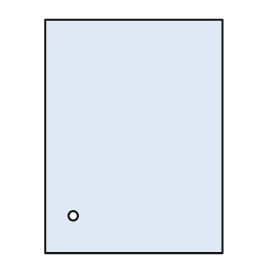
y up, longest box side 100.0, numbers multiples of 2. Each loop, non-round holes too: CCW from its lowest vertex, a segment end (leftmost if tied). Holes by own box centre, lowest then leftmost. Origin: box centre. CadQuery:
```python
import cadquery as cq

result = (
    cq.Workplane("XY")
    .moveTo(-38.0, -50.0)
    .lineTo(38.0, -50.0)
    .lineTo(38.0, 50.0)
    .lineTo(-38.0, 50.0)
    .close()
    .moveTo(-26.0, -34.0)
    .circle(2.0)
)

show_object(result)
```